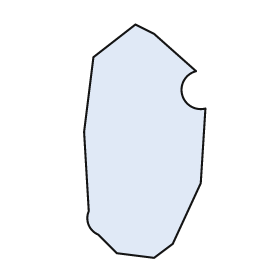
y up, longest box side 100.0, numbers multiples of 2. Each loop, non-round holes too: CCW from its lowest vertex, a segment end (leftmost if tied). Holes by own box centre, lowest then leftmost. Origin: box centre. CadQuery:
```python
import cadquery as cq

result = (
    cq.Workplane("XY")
    .moveTo(4.0, -50.0)
    .lineTo(12.0, -44.0)
    .lineTo(24.0, -18.0)
    .lineTo(26.0, 14.0)
    .threePointArc((16.0, 20.0), (22.0, 30.0))
    .lineTo(4.0, 46.0)
    .lineTo(-4.0, 50.0)
    .lineTo(-22.0, 36.0)
    .lineTo(-26.0, 4.0)
    .lineTo(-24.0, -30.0)
    .threePointArc((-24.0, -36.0), (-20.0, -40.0))
    .lineTo(-12.0, -48.0)
    .close()
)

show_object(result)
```